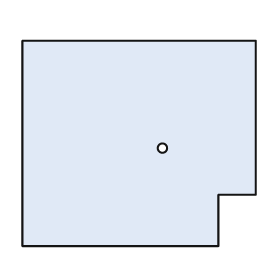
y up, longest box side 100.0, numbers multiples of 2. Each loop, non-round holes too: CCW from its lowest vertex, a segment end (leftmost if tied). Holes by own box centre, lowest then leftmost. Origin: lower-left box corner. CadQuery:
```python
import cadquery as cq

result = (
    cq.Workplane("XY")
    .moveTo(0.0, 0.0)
    .lineTo(84.0, 0.0)
    .lineTo(84.0, 22.0)
    .lineTo(100.0, 22.0)
    .lineTo(100.0, 88.0)
    .lineTo(0.0, 88.0)
    .close()
    .moveTo(60.0, 42.0)
    .circle(2.0)
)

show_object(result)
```